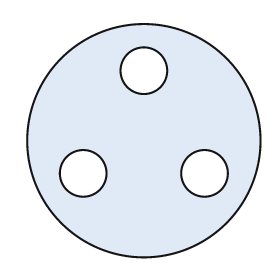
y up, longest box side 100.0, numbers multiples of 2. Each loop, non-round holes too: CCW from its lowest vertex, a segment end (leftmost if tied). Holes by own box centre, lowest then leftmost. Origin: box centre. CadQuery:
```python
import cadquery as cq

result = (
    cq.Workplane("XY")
    .moveTo(0.0, 0.0)
    .circle(50.0)
    .moveTo(-26.0, -14.0)
    .circle(10.0)
    .moveTo(26.0, -14.0)
    .circle(10.0)
    .moveTo(0.0, 30.0)
    .circle(10.0)
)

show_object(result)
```